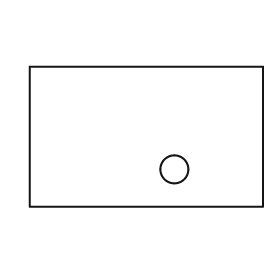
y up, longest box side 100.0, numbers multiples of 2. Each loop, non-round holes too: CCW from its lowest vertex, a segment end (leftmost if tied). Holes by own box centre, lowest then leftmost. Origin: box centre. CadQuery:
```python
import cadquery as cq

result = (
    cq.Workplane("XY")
    .moveTo(-50.0, -30.0)
    .lineTo(50.0, -30.0)
    .lineTo(50.0, 30.0)
    .lineTo(-50.0, 30.0)
    .close()
    .moveTo(12.0, -14.0)
    .circle(6.0)
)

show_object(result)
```